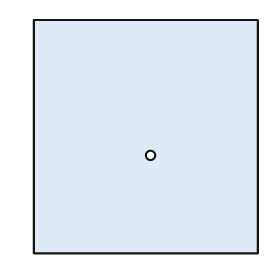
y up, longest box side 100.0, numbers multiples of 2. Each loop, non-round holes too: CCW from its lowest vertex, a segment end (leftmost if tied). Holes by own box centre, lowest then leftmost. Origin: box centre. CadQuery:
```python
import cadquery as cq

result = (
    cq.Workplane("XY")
    .moveTo(-48.0, -50.0)
    .lineTo(48.0, -50.0)
    .lineTo(48.0, 50.0)
    .lineTo(-48.0, 50.0)
    .close()
    .moveTo(2.0, -8.0)
    .circle(2.0)
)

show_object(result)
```